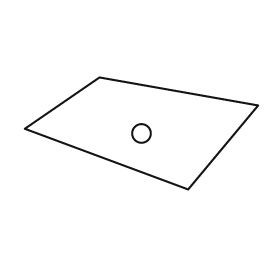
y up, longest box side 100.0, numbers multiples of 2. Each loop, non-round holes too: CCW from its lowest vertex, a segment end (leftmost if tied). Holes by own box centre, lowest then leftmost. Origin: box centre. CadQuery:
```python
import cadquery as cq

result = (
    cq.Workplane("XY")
    .moveTo(20.0, -24.0)
    .lineTo(50.0, 12.0)
    .lineTo(-18.0, 24.0)
    .lineTo(-50.0, 2.0)
    .close()
    .moveTo(0.0, 0.0)
    .circle(4.0)
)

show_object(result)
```